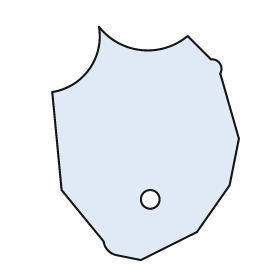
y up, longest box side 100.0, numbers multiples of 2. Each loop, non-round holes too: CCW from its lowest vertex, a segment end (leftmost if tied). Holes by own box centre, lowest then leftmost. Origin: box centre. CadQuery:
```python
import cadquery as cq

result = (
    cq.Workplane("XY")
    .moveTo(-2.0, -50.0)
    .lineTo(22.0, -38.0)
    .lineTo(36.0, -18.0)
    .lineTo(40.0, 2.0)
    .lineTo(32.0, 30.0)
    .threePointArc((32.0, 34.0), (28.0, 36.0))
    .lineTo(18.0, 46.0)
    .threePointArc((-2.0, 40.0), (-20.0, 50.0))
    .threePointArc((-24.0, 32.0), (-40.0, 22.0))
    .lineTo(-36.0, -20.0)
    .lineTo(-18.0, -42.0)
    .threePointArc((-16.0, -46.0), (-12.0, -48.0))
    .close()
    .moveTo(2.0, -24.0)
    .circle(4.0)
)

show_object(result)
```